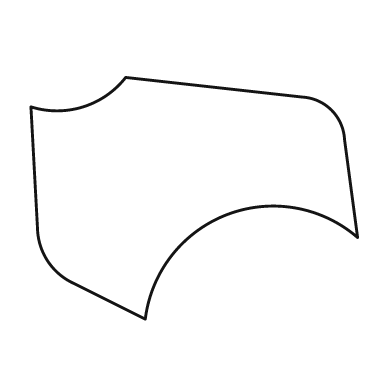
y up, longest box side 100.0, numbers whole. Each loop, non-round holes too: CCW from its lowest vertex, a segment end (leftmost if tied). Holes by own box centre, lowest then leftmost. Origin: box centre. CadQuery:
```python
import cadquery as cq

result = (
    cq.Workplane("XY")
    .moveTo(-15.0, -37.0)
    .threePointArc((10.0, -5.0), (50.0, -12.0))
    .lineTo(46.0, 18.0)
    .threePointArc((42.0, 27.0), (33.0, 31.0))
    .lineTo(-21.0, 37.0)
    .threePointArc((-34.0, 28.0), (-50.0, 28.0))
    .lineTo(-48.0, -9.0)
    .threePointArc((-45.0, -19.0), (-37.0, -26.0))
    .close()
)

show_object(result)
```